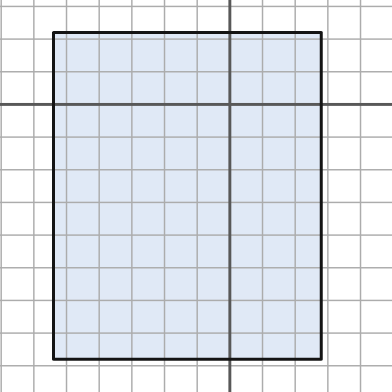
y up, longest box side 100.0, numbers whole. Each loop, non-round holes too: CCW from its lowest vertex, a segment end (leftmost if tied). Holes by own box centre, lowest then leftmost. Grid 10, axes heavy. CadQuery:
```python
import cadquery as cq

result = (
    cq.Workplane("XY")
    .moveTo(-54.0, -78.0)
    .lineTo(28.0, -78.0)
    .lineTo(28.0, 22.0)
    .lineTo(-54.0, 22.0)
    .close()
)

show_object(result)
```